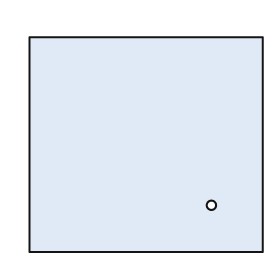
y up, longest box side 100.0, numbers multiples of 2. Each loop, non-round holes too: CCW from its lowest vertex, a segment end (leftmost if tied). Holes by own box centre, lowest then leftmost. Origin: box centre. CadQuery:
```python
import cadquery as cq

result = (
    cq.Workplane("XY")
    .moveTo(-50.0, -46.0)
    .lineTo(50.0, -46.0)
    .lineTo(50.0, 46.0)
    .lineTo(-50.0, 46.0)
    .close()
    .moveTo(28.0, -26.0)
    .circle(2.0)
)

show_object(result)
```